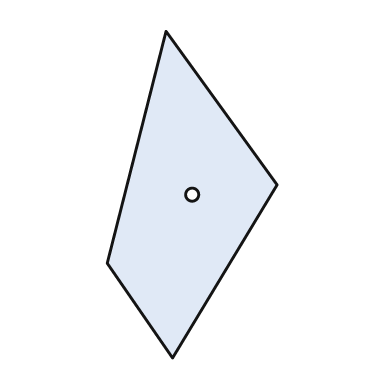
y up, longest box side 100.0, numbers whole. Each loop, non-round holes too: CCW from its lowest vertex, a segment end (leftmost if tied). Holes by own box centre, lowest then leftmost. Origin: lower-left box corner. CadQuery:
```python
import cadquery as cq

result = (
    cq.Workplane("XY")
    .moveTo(20.0, 0.0)
    .lineTo(52.0, 53.0)
    .lineTo(18.0, 100.0)
    .lineTo(0.0, 29.0)
    .close()
    .moveTo(26.0, 50.0)
    .circle(2.0)
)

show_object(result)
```